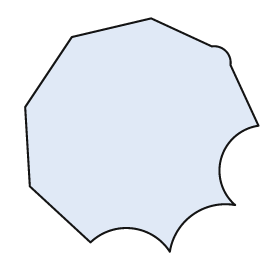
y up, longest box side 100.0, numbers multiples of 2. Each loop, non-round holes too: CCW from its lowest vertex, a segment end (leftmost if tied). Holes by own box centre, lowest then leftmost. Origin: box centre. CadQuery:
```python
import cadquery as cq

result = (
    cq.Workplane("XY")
    .moveTo(12.0, -50.0)
    .threePointArc((22.0, -34.0), (40.0, -30.0))
    .threePointArc((34.0, -10.0), (50.0, 4.0))
    .lineTo(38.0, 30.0)
    .threePointArc((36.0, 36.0), (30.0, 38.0))
    .lineTo(4.0, 50.0)
    .lineTo(-30.0, 42.0)
    .lineTo(-50.0, 12.0)
    .lineTo(-48.0, -22.0)
    .lineTo(-22.0, -46.0)
    .threePointArc((-4.0, -40.0), (12.0, -50.0))
    .close()
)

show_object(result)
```